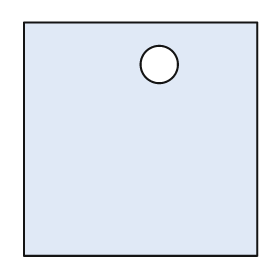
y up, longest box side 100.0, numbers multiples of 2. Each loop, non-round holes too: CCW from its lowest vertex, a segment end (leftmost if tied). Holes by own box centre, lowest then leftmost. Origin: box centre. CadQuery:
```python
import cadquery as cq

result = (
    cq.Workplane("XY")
    .moveTo(-50.0, -50.0)
    .lineTo(50.0, -50.0)
    .lineTo(50.0, 50.0)
    .lineTo(-50.0, 50.0)
    .close()
    .moveTo(8.0, 32.0)
    .circle(8.0)
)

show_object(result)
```